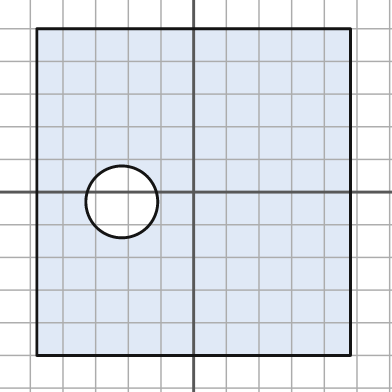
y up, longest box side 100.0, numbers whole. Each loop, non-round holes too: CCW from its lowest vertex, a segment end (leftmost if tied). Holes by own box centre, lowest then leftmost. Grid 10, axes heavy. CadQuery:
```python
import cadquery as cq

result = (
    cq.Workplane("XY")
    .moveTo(-48.0, -50.0)
    .lineTo(48.0, -50.0)
    .lineTo(48.0, 50.0)
    .lineTo(-48.0, 50.0)
    .close()
    .moveTo(-22.0, -3.0)
    .circle(11.0)
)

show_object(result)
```